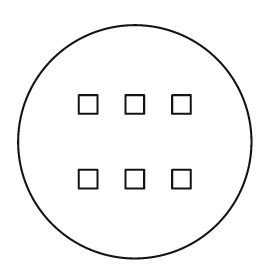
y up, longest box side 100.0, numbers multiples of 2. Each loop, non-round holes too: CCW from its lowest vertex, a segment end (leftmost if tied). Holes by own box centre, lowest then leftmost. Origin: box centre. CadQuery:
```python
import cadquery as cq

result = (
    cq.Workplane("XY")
    .moveTo(0.0, 0.0)
    .circle(50.0)
    .moveTo(-24.0, -20.0)
    .lineTo(-16.0, -20.0)
    .lineTo(-16.0, -12.0)
    .lineTo(-24.0, -12.0)
    .close()
    .moveTo(-4.0, -20.0)
    .lineTo(4.0, -20.0)
    .lineTo(4.0, -12.0)
    .lineTo(-4.0, -12.0)
    .close()
    .moveTo(16.0, -20.0)
    .lineTo(24.0, -20.0)
    .lineTo(24.0, -12.0)
    .lineTo(16.0, -12.0)
    .close()
    .moveTo(-24.0, 12.0)
    .lineTo(-16.0, 12.0)
    .lineTo(-16.0, 20.0)
    .lineTo(-24.0, 20.0)
    .close()
    .moveTo(-4.0, 12.0)
    .lineTo(4.0, 12.0)
    .lineTo(4.0, 20.0)
    .lineTo(-4.0, 20.0)
    .close()
    .moveTo(16.0, 12.0)
    .lineTo(24.0, 12.0)
    .lineTo(24.0, 20.0)
    .lineTo(16.0, 20.0)
    .close()
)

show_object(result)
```